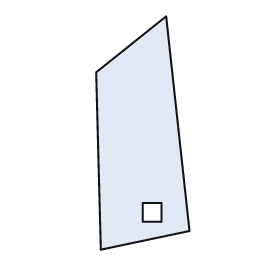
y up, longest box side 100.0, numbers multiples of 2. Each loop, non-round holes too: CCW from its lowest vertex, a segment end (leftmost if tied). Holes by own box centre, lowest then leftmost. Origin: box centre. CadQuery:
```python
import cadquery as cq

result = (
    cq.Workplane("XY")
    .moveTo(-18.0, -50.0)
    .lineTo(20.0, -42.0)
    .lineTo(10.0, 50.0)
    .lineTo(-20.0, 26.0)
    .close()
    .moveTo(0.0, -38.0)
    .lineTo(8.0, -38.0)
    .lineTo(8.0, -30.0)
    .lineTo(0.0, -30.0)
    .close()
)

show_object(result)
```